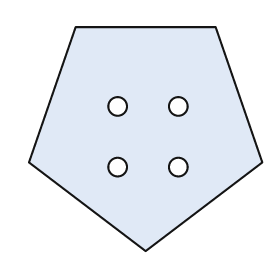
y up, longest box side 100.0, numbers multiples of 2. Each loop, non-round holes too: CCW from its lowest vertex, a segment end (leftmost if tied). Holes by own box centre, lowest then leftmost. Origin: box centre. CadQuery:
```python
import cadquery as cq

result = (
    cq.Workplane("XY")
    .moveTo(0.0, -48.0)
    .lineTo(50.0, -10.0)
    .lineTo(30.0, 48.0)
    .lineTo(-30.0, 48.0)
    .lineTo(-50.0, -10.0)
    .close()
    .moveTo(-12.0, -12.0)
    .circle(4.0)
    .moveTo(14.0, -12.0)
    .circle(4.0)
    .moveTo(-12.0, 14.0)
    .circle(4.0)
    .moveTo(14.0, 14.0)
    .circle(4.0)
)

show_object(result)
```